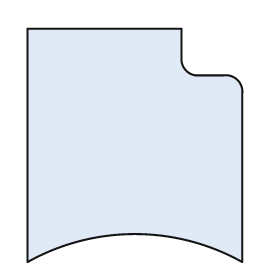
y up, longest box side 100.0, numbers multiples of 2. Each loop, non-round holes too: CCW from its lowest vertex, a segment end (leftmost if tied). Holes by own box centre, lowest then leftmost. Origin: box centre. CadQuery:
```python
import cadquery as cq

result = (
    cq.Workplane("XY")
    .moveTo(-46.0, -50.0)
    .threePointArc((0.0, -38.0), (46.0, -50.0))
    .lineTo(46.0, 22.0)
    .threePointArc((44.0, 28.0), (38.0, 30.0))
    .lineTo(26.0, 30.0)
    .threePointArc((22.0, 32.0), (20.0, 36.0))
    .lineTo(20.0, 50.0)
    .lineTo(-46.0, 50.0)
    .close()
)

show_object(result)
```